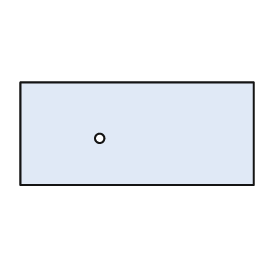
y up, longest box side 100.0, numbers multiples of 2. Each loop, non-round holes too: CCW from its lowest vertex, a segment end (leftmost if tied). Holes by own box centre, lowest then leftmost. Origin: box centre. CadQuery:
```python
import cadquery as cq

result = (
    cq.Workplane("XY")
    .moveTo(-50.0, -22.0)
    .lineTo(50.0, -22.0)
    .lineTo(50.0, 22.0)
    .lineTo(-50.0, 22.0)
    .close()
    .moveTo(-16.0, -2.0)
    .circle(2.0)
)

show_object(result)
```